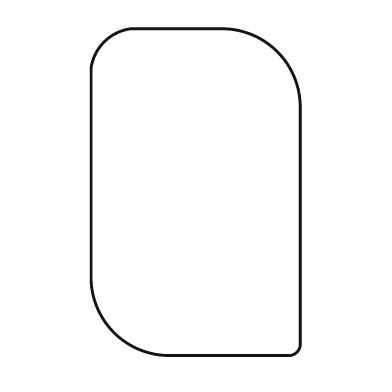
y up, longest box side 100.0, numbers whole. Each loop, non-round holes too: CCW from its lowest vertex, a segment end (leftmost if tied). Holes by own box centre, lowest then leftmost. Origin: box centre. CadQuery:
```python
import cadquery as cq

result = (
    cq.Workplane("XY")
    .moveTo(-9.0, -50.0)
    .lineTo(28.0, -50.0)
    .threePointArc((31.0, -49.0), (32.0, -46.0))
    .lineTo(32.0, 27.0)
    .threePointArc((25.0, 43.0), (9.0, 50.0))
    .lineTo(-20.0, 50.0)
    .threePointArc((-28.0, 46.0), (-32.0, 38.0))
    .lineTo(-32.0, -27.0)
    .threePointArc((-25.0, -43.0), (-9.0, -50.0))
    .close()
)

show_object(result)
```